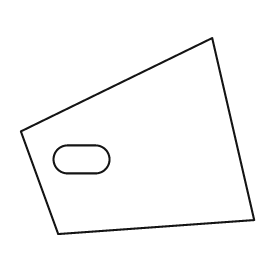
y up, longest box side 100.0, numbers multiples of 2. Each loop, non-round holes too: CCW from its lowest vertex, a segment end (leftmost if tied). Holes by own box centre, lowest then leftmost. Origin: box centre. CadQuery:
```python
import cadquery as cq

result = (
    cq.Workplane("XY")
    .moveTo(-34.0, -42.0)
    .lineTo(50.0, -36.0)
    .lineTo(32.0, 42.0)
    .lineTo(-50.0, 2.0)
    .close()
    .moveTo(-30.0, -16.0)
    .lineTo(-18.0, -16.0)
    .threePointArc((-12.0, -10.0), (-18.0, -4.0))
    .lineTo(-30.0, -4.0)
    .threePointArc((-36.0, -10.0), (-30.0, -16.0))
    .close()
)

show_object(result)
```